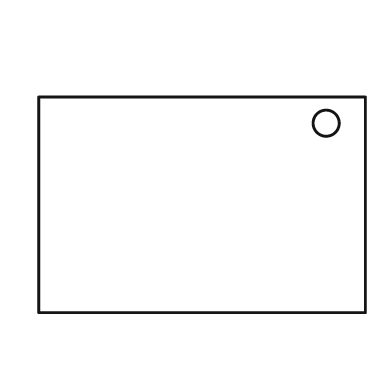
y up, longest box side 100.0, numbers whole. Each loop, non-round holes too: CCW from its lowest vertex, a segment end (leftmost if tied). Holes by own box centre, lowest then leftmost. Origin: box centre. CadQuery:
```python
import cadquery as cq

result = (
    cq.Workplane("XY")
    .moveTo(-50.0, -33.0)
    .lineTo(50.0, -33.0)
    .lineTo(50.0, 33.0)
    .lineTo(-50.0, 33.0)
    .close()
    .moveTo(38.0, 25.0)
    .circle(4.0)
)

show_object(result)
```